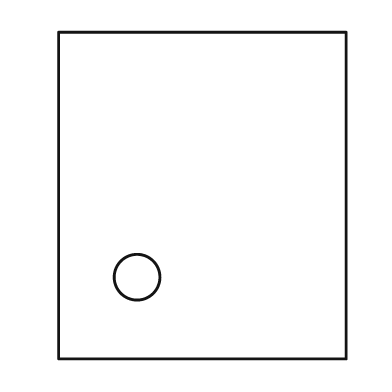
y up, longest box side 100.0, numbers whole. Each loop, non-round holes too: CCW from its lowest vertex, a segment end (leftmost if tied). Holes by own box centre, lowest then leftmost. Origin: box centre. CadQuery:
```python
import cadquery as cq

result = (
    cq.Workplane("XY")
    .moveTo(-44.0, -50.0)
    .lineTo(44.0, -50.0)
    .lineTo(44.0, 50.0)
    .lineTo(-44.0, 50.0)
    .close()
    .moveTo(-20.0, -25.0)
    .circle(7.0)
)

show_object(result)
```